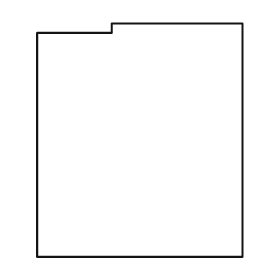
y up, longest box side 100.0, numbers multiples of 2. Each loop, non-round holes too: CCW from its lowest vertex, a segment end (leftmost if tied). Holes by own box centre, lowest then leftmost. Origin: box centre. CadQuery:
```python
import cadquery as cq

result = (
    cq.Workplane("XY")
    .moveTo(-44.0, -50.0)
    .lineTo(44.0, -50.0)
    .lineTo(44.0, 50.0)
    .lineTo(-12.0, 50.0)
    .lineTo(-12.0, 46.0)
    .lineTo(-44.0, 46.0)
    .close()
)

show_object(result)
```